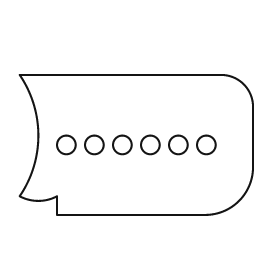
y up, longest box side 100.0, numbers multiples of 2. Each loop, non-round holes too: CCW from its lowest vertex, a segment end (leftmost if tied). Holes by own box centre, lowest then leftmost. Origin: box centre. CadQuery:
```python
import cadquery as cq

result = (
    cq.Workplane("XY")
    .moveTo(-34.0, -30.0)
    .lineTo(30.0, -30.0)
    .threePointArc((44.0, -24.0), (50.0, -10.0))
    .lineTo(50.0, 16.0)
    .threePointArc((46.0, 26.0), (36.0, 30.0))
    .lineTo(-50.0, 30.0)
    .threePointArc((-42.0, 4.0), (-50.0, -22.0))
    .threePointArc((-42.0, -24.0), (-34.0, -22.0))
    .close()
    .moveTo(-30.0, 0.0)
    .circle(4.0)
    .moveTo(-18.0, 0.0)
    .circle(4.0)
    .moveTo(-6.0, 0.0)
    .circle(4.0)
    .moveTo(6.0, 0.0)
    .circle(4.0)
    .moveTo(18.0, 0.0)
    .circle(4.0)
    .moveTo(30.0, 0.0)
    .circle(4.0)
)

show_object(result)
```